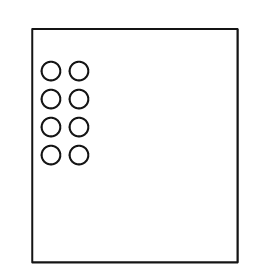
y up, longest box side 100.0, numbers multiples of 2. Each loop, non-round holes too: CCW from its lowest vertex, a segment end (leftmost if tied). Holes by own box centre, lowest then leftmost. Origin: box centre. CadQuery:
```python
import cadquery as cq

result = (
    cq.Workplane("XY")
    .moveTo(-44.0, -50.0)
    .lineTo(44.0, -50.0)
    .lineTo(44.0, 50.0)
    .lineTo(-44.0, 50.0)
    .close()
    .moveTo(-36.0, -4.0)
    .circle(4.0)
    .moveTo(-24.0, -4.0)
    .circle(4.0)
    .moveTo(-36.0, 8.0)
    .circle(4.0)
    .moveTo(-24.0, 8.0)
    .circle(4.0)
    .moveTo(-36.0, 20.0)
    .circle(4.0)
    .moveTo(-24.0, 20.0)
    .circle(4.0)
    .moveTo(-36.0, 32.0)
    .circle(4.0)
    .moveTo(-24.0, 32.0)
    .circle(4.0)
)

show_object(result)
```